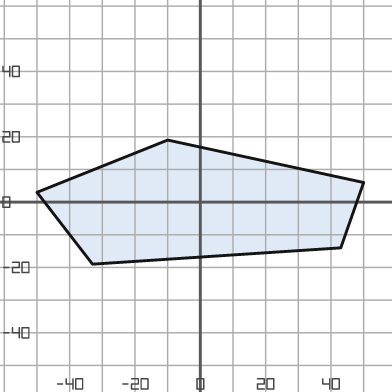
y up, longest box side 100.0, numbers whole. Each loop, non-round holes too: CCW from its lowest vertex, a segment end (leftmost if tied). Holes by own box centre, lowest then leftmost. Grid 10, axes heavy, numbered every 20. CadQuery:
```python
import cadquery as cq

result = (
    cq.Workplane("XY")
    .moveTo(-33.0, -19.0)
    .lineTo(43.0, -14.0)
    .lineTo(50.0, 6.0)
    .lineTo(-10.0, 19.0)
    .lineTo(-50.0, 3.0)
    .close()
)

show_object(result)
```